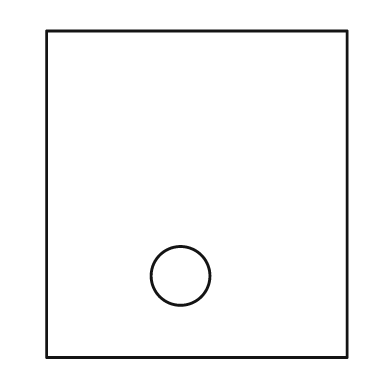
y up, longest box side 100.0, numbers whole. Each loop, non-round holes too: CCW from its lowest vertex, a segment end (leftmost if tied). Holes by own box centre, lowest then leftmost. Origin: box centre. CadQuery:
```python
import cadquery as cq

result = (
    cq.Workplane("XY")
    .moveTo(-46.0, -50.0)
    .lineTo(46.0, -50.0)
    .lineTo(46.0, 50.0)
    .lineTo(-46.0, 50.0)
    .close()
    .moveTo(-5.0, -25.0)
    .circle(9.0)
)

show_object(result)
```